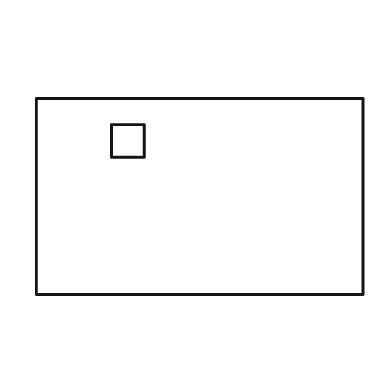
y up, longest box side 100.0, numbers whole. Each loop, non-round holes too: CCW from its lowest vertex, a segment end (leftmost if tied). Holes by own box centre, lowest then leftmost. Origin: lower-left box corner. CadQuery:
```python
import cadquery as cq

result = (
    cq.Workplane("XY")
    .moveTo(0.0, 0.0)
    .lineTo(100.0, 0.0)
    .lineTo(100.0, 60.0)
    .lineTo(0.0, 60.0)
    .close()
    .moveTo(23.0, 42.0)
    .lineTo(33.0, 42.0)
    .lineTo(33.0, 52.0)
    .lineTo(23.0, 52.0)
    .close()
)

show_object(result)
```